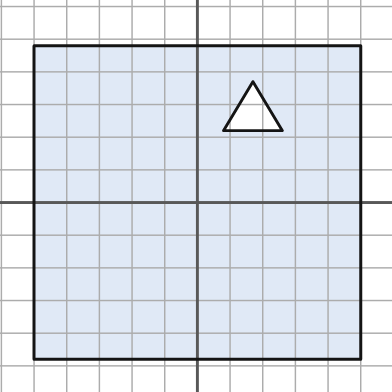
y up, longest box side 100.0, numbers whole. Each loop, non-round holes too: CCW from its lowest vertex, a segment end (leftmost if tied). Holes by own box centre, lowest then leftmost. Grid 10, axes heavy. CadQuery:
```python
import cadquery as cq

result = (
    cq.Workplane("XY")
    .moveTo(-50.0, -48.0)
    .lineTo(50.0, -48.0)
    .lineTo(50.0, 48.0)
    .lineTo(-50.0, 48.0)
    .close()
    .moveTo(8.0, 22.0)
    .lineTo(26.0, 22.0)
    .lineTo(17.0, 37.0)
    .close()
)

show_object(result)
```